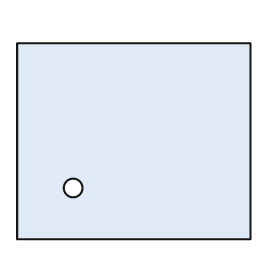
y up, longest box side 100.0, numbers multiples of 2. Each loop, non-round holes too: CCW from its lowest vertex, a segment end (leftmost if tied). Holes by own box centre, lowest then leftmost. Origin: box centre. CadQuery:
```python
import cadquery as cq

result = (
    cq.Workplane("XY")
    .moveTo(-50.0, -42.0)
    .lineTo(50.0, -42.0)
    .lineTo(50.0, 42.0)
    .lineTo(-50.0, 42.0)
    .close()
    .moveTo(-26.0, -20.0)
    .circle(4.0)
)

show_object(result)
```